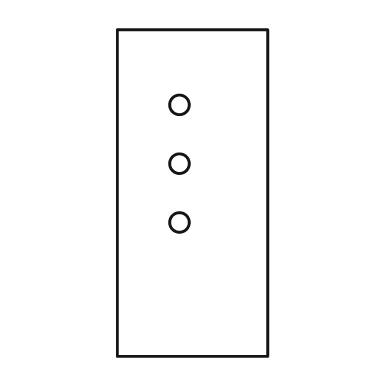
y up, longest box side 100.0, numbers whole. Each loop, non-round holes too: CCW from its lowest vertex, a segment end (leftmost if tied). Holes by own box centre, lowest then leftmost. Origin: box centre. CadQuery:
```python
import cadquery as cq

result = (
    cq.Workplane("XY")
    .moveTo(-23.0, -50.0)
    .lineTo(23.0, -50.0)
    .lineTo(23.0, 50.0)
    .lineTo(-23.0, 50.0)
    .close()
    .moveTo(-4.0, -9.0)
    .circle(3.0)
    .moveTo(-4.0, 9.0)
    .circle(3.0)
    .moveTo(-4.0, 27.0)
    .circle(3.0)
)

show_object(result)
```